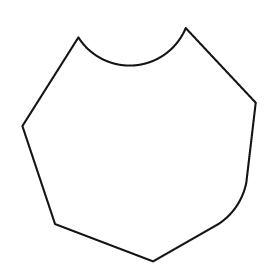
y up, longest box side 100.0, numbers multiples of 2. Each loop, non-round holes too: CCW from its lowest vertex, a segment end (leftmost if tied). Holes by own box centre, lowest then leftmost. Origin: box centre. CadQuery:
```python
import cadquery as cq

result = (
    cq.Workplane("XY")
    .moveTo(6.0, -50.0)
    .lineTo(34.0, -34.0)
    .threePointArc((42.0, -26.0), (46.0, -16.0))
    .lineTo(50.0, 18.0)
    .lineTo(20.0, 50.0)
    .threePointArc((-2.0, 34.0), (-26.0, 46.0))
    .lineTo(-50.0, 8.0)
    .lineTo(-36.0, -34.0)
    .close()
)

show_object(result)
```